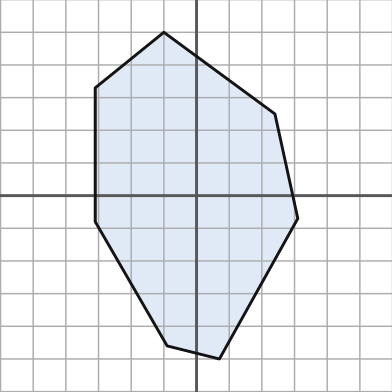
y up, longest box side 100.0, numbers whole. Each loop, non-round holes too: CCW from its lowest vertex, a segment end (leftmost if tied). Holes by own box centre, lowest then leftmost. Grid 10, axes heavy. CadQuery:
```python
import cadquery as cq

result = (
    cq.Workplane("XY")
    .moveTo(7.0, -50.0)
    .lineTo(31.0, -7.0)
    .lineTo(24.0, 25.0)
    .lineTo(-10.0, 50.0)
    .lineTo(-31.0, 33.0)
    .lineTo(-31.0, -8.0)
    .lineTo(-9.0, -46.0)
    .close()
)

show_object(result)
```